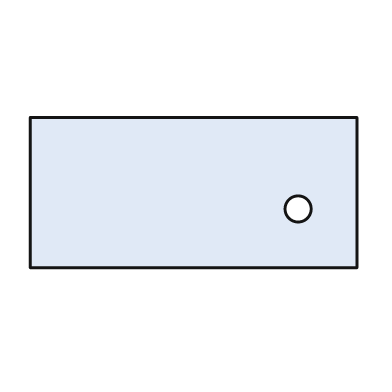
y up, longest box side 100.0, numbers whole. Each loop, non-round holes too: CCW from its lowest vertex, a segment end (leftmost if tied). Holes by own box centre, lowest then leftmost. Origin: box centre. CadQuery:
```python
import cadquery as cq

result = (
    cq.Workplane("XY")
    .moveTo(-50.0, -23.0)
    .lineTo(50.0, -23.0)
    .lineTo(50.0, 23.0)
    .lineTo(-50.0, 23.0)
    .close()
    .moveTo(32.0, -5.0)
    .circle(4.0)
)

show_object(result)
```